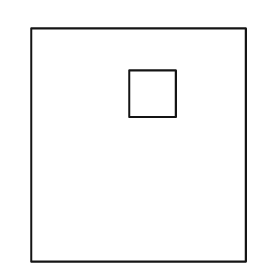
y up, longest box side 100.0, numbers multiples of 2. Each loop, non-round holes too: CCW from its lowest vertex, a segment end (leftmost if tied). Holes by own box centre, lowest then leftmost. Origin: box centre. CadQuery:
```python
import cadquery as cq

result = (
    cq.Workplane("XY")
    .moveTo(-46.0, -50.0)
    .lineTo(46.0, -50.0)
    .lineTo(46.0, 50.0)
    .lineTo(-46.0, 50.0)
    .close()
    .moveTo(-4.0, 12.0)
    .lineTo(16.0, 12.0)
    .lineTo(16.0, 32.0)
    .lineTo(-4.0, 32.0)
    .close()
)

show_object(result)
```